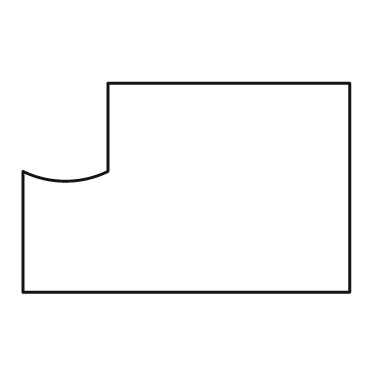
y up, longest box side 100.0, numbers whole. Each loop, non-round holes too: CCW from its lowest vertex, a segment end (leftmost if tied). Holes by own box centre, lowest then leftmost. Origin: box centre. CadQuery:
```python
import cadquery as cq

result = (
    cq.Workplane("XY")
    .moveTo(-50.0, -32.0)
    .lineTo(50.0, -32.0)
    .lineTo(50.0, 32.0)
    .lineTo(-24.0, 32.0)
    .lineTo(-24.0, 5.0)
    .threePointArc((-37.0, 2.0), (-50.0, 5.0))
    .close()
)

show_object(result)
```